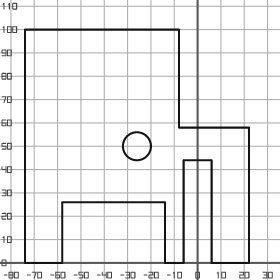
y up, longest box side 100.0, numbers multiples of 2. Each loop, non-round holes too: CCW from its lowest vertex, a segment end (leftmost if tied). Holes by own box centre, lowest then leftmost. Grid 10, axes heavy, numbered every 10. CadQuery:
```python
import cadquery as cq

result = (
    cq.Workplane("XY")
    .moveTo(-74.0, 0.0)
    .lineTo(-58.0, 0.0)
    .lineTo(-58.0, 26.0)
    .lineTo(-14.0, 26.0)
    .lineTo(-14.0, 0.0)
    .lineTo(-6.0, 0.0)
    .lineTo(-6.0, 44.0)
    .lineTo(6.0, 44.0)
    .lineTo(6.0, 0.0)
    .lineTo(22.0, 0.0)
    .lineTo(22.0, 58.0)
    .lineTo(-8.0, 58.0)
    .lineTo(-8.0, 100.0)
    .lineTo(-74.0, 100.0)
    .close()
    .moveTo(-26.0, 50.0)
    .circle(6.0)
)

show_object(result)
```